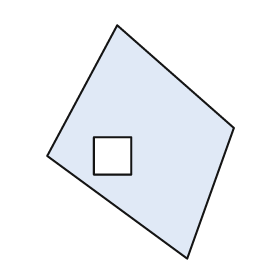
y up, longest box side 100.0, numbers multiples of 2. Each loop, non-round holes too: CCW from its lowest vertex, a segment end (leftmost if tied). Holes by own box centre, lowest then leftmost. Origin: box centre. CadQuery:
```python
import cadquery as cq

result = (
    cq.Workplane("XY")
    .moveTo(20.0, -50.0)
    .lineTo(40.0, 6.0)
    .lineTo(-10.0, 50.0)
    .lineTo(-40.0, -6.0)
    .close()
    .moveTo(-20.0, -14.0)
    .lineTo(-4.0, -14.0)
    .lineTo(-4.0, 2.0)
    .lineTo(-20.0, 2.0)
    .close()
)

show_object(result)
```